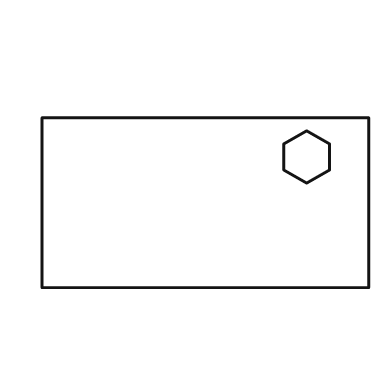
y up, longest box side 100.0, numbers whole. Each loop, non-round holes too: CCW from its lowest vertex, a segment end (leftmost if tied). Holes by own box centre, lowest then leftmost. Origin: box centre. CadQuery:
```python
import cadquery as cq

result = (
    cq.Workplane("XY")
    .moveTo(-50.0, -26.0)
    .lineTo(50.0, -26.0)
    .lineTo(50.0, 26.0)
    .lineTo(-50.0, 26.0)
    .close()
    .moveTo(31.0, 6.0)
    .lineTo(38.0, 10.0)
    .lineTo(38.0, 18.0)
    .lineTo(31.0, 22.0)
    .lineTo(24.0, 18.0)
    .lineTo(24.0, 10.0)
    .close()
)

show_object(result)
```